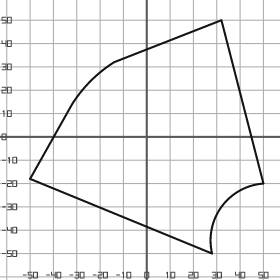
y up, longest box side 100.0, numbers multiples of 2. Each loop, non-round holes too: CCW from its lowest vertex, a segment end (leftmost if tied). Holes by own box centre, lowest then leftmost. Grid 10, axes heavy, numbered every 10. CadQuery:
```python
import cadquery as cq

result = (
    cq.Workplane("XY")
    .moveTo(28.0, -50.0)
    .threePointArc((32.0, -30.0), (50.0, -20.0))
    .lineTo(32.0, 50.0)
    .lineTo(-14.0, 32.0)
    .threePointArc((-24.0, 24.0), (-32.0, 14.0))
    .lineTo(-50.0, -18.0)
    .close()
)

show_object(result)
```